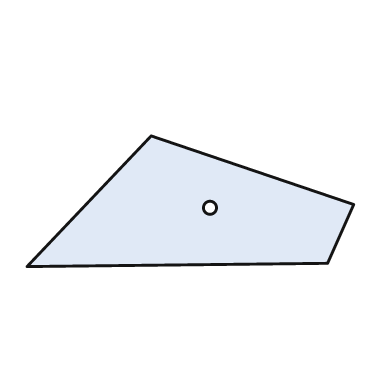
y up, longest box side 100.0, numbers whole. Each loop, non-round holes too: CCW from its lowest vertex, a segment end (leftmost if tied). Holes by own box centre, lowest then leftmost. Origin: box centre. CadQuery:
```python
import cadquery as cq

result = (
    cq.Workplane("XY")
    .moveTo(-50.0, -20.0)
    .lineTo(42.0, -19.0)
    .lineTo(50.0, -1.0)
    .lineTo(-12.0, 20.0)
    .close()
    .moveTo(6.0, -2.0)
    .circle(2.0)
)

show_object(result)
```